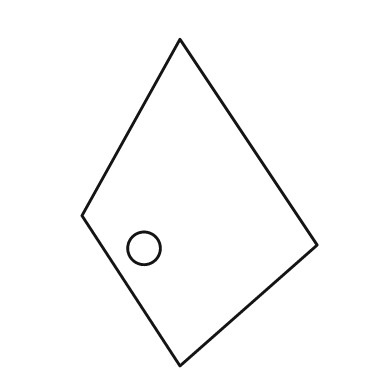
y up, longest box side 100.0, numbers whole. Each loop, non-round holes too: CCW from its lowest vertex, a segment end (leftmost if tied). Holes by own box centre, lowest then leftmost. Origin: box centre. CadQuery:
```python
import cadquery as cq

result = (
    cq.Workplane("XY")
    .moveTo(-6.0, -50.0)
    .lineTo(36.0, -13.0)
    .lineTo(-6.0, 50.0)
    .lineTo(-36.0, -4.0)
    .close()
    .moveTo(-17.0, -14.0)
    .circle(5.0)
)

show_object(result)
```